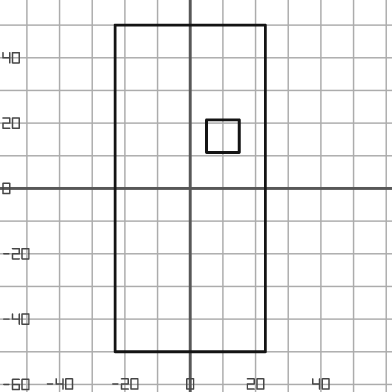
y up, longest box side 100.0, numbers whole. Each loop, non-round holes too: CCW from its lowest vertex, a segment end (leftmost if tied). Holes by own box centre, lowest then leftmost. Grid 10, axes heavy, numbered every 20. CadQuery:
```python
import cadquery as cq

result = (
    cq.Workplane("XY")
    .moveTo(-23.0, -50.0)
    .lineTo(23.0, -50.0)
    .lineTo(23.0, 50.0)
    .lineTo(-23.0, 50.0)
    .close()
    .moveTo(5.0, 11.0)
    .lineTo(15.0, 11.0)
    .lineTo(15.0, 21.0)
    .lineTo(5.0, 21.0)
    .close()
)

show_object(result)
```